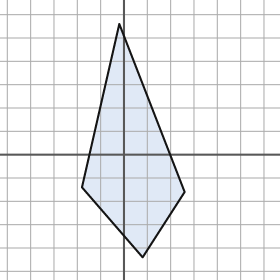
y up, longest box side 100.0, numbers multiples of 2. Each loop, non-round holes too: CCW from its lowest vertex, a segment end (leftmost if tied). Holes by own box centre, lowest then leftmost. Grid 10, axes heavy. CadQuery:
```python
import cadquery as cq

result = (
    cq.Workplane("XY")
    .moveTo(8.0, -44.0)
    .lineTo(26.0, -16.0)
    .lineTo(-2.0, 56.0)
    .lineTo(-18.0, -14.0)
    .close()
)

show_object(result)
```